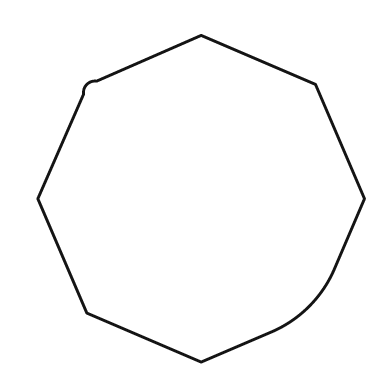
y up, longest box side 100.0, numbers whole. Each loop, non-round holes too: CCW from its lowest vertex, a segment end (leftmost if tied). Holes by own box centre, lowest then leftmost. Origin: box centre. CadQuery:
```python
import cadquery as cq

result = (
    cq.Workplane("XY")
    .moveTo(0.0, -50.0)
    .lineTo(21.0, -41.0)
    .threePointArc((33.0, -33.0), (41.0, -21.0))
    .lineTo(50.0, 0.0)
    .lineTo(35.0, 35.0)
    .lineTo(0.0, 50.0)
    .lineTo(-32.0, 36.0)
    .threePointArc((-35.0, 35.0), (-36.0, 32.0))
    .lineTo(-50.0, 0.0)
    .lineTo(-35.0, -35.0)
    .close()
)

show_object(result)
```